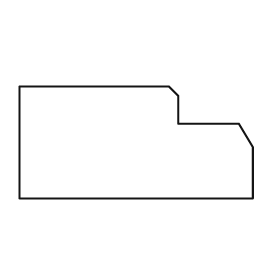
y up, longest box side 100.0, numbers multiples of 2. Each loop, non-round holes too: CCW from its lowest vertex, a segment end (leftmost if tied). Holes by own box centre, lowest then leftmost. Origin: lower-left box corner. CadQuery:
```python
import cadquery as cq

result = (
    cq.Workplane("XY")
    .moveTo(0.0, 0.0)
    .lineTo(100.0, 0.0)
    .lineTo(100.0, 22.0)
    .lineTo(94.0, 32.0)
    .lineTo(68.0, 32.0)
    .lineTo(68.0, 44.0)
    .lineTo(64.0, 48.0)
    .lineTo(0.0, 48.0)
    .close()
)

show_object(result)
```